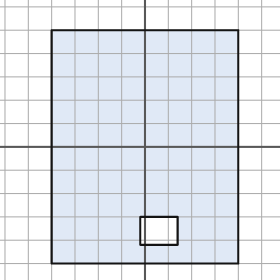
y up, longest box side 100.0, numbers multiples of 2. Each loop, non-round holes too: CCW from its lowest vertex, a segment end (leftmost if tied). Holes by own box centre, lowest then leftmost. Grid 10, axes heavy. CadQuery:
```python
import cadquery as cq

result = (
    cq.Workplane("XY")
    .moveTo(-40.0, -50.0)
    .lineTo(40.0, -50.0)
    .lineTo(40.0, 50.0)
    .lineTo(-40.0, 50.0)
    .close()
    .moveTo(-2.0, -42.0)
    .lineTo(14.0, -42.0)
    .lineTo(14.0, -30.0)
    .lineTo(-2.0, -30.0)
    .close()
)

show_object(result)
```